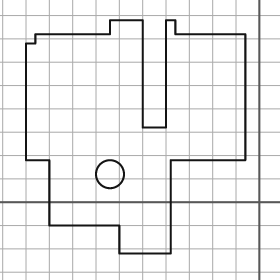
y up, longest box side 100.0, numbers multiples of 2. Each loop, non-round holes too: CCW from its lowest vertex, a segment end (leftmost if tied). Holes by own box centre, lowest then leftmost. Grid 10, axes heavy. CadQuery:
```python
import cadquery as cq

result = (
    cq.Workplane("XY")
    .moveTo(-60.0, -22.0)
    .lineTo(-38.0, -22.0)
    .lineTo(-38.0, 18.0)
    .lineTo(-6.0, 18.0)
    .lineTo(-6.0, 72.0)
    .lineTo(-36.0, 72.0)
    .lineTo(-36.0, 78.0)
    .lineTo(-40.0, 78.0)
    .lineTo(-40.0, 32.0)
    .lineTo(-50.0, 32.0)
    .lineTo(-50.0, 78.0)
    .lineTo(-64.0, 78.0)
    .lineTo(-64.0, 72.0)
    .lineTo(-96.0, 72.0)
    .lineTo(-96.0, 68.0)
    .lineTo(-100.0, 68.0)
    .lineTo(-100.0, 18.0)
    .lineTo(-90.0, 18.0)
    .lineTo(-90.0, -10.0)
    .lineTo(-60.0, -10.0)
    .close()
    .moveTo(-64.0, 12.0)
    .circle(6.0)
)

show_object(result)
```